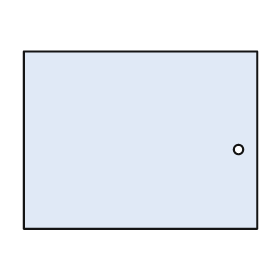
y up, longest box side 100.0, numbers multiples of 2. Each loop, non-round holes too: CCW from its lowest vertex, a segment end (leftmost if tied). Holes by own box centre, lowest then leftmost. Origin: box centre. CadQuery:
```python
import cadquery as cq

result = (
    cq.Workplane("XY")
    .moveTo(-50.0, -38.0)
    .lineTo(50.0, -38.0)
    .lineTo(50.0, 38.0)
    .lineTo(-50.0, 38.0)
    .close()
    .moveTo(42.0, -4.0)
    .circle(2.0)
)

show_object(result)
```